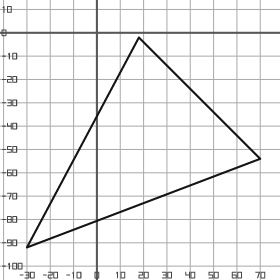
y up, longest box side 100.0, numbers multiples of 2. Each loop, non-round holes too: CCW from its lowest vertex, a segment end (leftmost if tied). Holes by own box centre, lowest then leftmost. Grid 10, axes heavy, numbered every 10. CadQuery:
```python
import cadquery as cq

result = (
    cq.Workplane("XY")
    .moveTo(-30.0, -92.0)
    .lineTo(70.0, -54.0)
    .lineTo(18.0, -2.0)
    .close()
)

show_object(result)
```